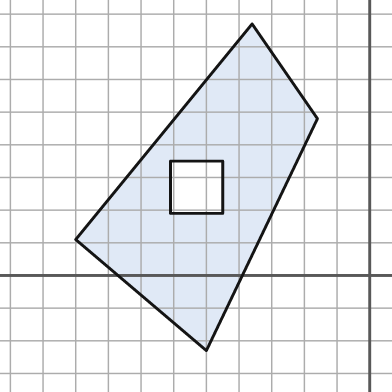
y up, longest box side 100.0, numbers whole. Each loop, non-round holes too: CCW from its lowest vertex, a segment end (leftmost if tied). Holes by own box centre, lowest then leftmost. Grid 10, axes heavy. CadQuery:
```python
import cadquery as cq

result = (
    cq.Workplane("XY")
    .moveTo(-50.0, -23.0)
    .lineTo(-16.0, 48.0)
    .lineTo(-36.0, 77.0)
    .lineTo(-90.0, 11.0)
    .close()
    .moveTo(-61.0, 19.0)
    .lineTo(-45.0, 19.0)
    .lineTo(-45.0, 35.0)
    .lineTo(-61.0, 35.0)
    .close()
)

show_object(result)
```